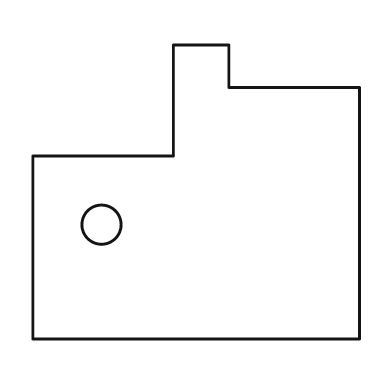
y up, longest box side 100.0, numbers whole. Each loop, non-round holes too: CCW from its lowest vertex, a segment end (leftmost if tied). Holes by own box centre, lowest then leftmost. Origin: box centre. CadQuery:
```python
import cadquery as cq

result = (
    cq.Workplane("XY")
    .moveTo(-50.0, -45.0)
    .lineTo(50.0, -45.0)
    .lineTo(50.0, 32.0)
    .lineTo(10.0, 32.0)
    .lineTo(10.0, 45.0)
    .lineTo(-7.0, 45.0)
    .lineTo(-7.0, 11.0)
    .lineTo(-50.0, 11.0)
    .close()
    .moveTo(-29.0, -10.0)
    .circle(6.0)
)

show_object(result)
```